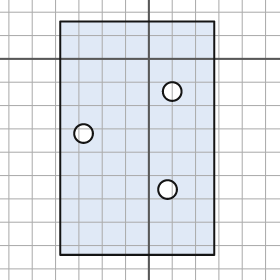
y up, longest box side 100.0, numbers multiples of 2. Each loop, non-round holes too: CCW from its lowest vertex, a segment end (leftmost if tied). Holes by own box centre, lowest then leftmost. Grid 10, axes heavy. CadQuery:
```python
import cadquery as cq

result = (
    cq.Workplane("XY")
    .moveTo(-38.0, -84.0)
    .lineTo(28.0, -84.0)
    .lineTo(28.0, 16.0)
    .lineTo(-38.0, 16.0)
    .close()
    .moveTo(8.0, -56.0)
    .circle(4.0)
    .moveTo(-28.0, -32.0)
    .circle(4.0)
    .moveTo(10.0, -14.0)
    .circle(4.0)
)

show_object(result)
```